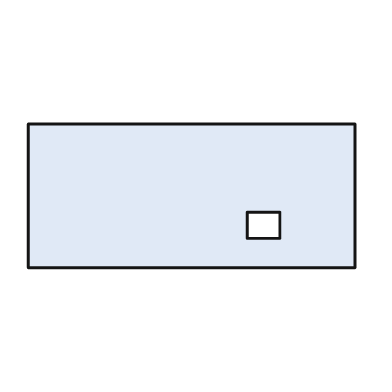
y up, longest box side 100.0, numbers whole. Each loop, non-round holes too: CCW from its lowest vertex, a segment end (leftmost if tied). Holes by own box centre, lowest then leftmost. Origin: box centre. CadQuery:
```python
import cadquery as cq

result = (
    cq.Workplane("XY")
    .moveTo(-50.0, -22.0)
    .lineTo(50.0, -22.0)
    .lineTo(50.0, 22.0)
    .lineTo(-50.0, 22.0)
    .close()
    .moveTo(17.0, -13.0)
    .lineTo(27.0, -13.0)
    .lineTo(27.0, -5.0)
    .lineTo(17.0, -5.0)
    .close()
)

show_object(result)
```